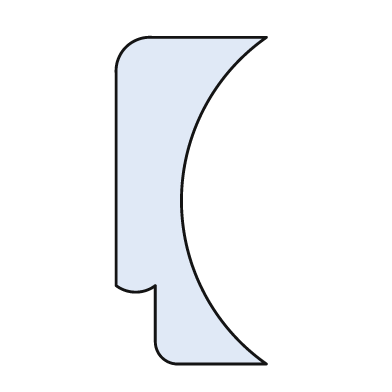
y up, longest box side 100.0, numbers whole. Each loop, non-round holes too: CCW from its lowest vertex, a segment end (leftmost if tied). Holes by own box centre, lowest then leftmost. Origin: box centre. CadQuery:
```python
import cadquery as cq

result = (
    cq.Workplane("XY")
    .moveTo(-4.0, -50.0)
    .lineTo(23.0, -50.0)
    .threePointArc((-3.0, 0.0), (23.0, 50.0))
    .lineTo(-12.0, 50.0)
    .threePointArc((-20.0, 47.0), (-23.0, 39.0))
    .lineTo(-23.0, -26.0)
    .threePointArc((-17.0, -28.0), (-11.0, -26.0))
    .lineTo(-11.0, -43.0)
    .threePointArc((-9.0, -48.0), (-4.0, -50.0))
    .close()
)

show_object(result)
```